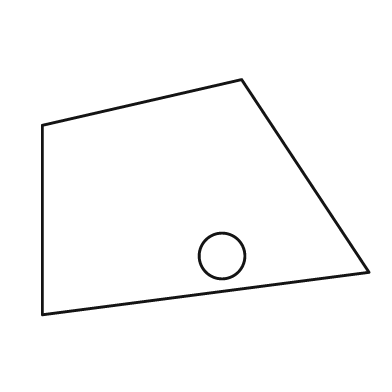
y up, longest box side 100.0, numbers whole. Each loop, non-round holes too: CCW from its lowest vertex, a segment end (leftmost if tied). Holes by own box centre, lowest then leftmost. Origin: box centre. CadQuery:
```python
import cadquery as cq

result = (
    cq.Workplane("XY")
    .moveTo(-50.0, -36.0)
    .lineTo(50.0, -23.0)
    .lineTo(11.0, 36.0)
    .lineTo(-50.0, 22.0)
    .close()
    .moveTo(5.0, -18.0)
    .circle(7.0)
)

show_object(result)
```